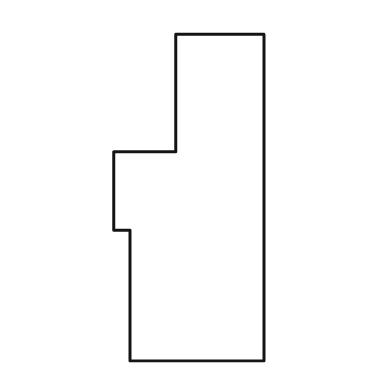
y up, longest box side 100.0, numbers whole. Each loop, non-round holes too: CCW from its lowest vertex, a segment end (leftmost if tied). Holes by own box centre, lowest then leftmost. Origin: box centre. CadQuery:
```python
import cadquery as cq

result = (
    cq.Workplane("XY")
    .moveTo(-18.0, -50.0)
    .lineTo(23.0, -50.0)
    .lineTo(23.0, 50.0)
    .lineTo(-4.0, 50.0)
    .lineTo(-4.0, 14.0)
    .lineTo(-23.0, 14.0)
    .lineTo(-23.0, -10.0)
    .lineTo(-18.0, -10.0)
    .close()
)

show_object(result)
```